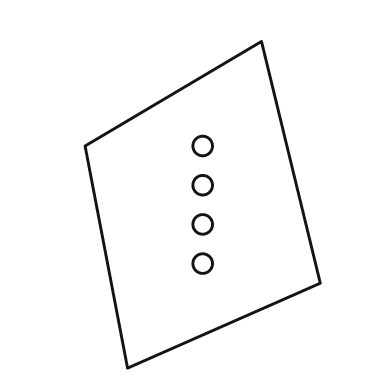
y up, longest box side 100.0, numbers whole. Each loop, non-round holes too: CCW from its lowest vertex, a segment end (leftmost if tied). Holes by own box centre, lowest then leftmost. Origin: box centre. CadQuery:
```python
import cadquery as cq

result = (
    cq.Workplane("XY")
    .moveTo(-23.0, -50.0)
    .lineTo(36.0, -24.0)
    .lineTo(18.0, 50.0)
    .lineTo(-36.0, 18.0)
    .close()
    .moveTo(0.0, -18.0)
    .circle(3.0)
    .moveTo(0.0, -6.0)
    .circle(3.0)
    .moveTo(0.0, 6.0)
    .circle(3.0)
    .moveTo(0.0, 18.0)
    .circle(3.0)
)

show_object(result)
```